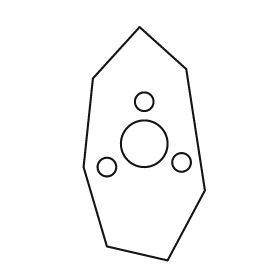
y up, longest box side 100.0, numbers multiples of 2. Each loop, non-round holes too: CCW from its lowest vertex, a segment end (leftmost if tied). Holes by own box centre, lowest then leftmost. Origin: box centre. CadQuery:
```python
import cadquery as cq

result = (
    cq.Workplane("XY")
    .moveTo(10.0, -50.0)
    .lineTo(26.0, -20.0)
    .lineTo(18.0, 32.0)
    .lineTo(-2.0, 50.0)
    .lineTo(-22.0, 28.0)
    .lineTo(-26.0, -10.0)
    .lineTo(-16.0, -44.0)
    .close()
    .moveTo(-16.0, -10.0)
    .circle(4.0)
    .moveTo(16.0, -8.0)
    .circle(4.0)
    .moveTo(0.0, 0.0)
    .circle(10.0)
    .moveTo(0.0, 18.0)
    .circle(4.0)
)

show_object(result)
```